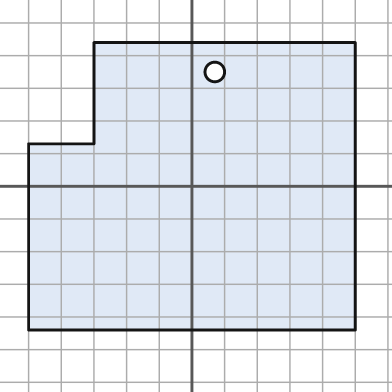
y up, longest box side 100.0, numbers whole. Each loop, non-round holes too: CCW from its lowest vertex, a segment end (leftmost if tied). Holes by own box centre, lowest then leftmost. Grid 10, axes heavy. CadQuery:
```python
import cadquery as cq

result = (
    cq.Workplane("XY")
    .moveTo(-50.0, -44.0)
    .lineTo(50.0, -44.0)
    .lineTo(50.0, 44.0)
    .lineTo(-30.0, 44.0)
    .lineTo(-30.0, 13.0)
    .lineTo(-50.0, 13.0)
    .close()
    .moveTo(7.0, 35.0)
    .circle(3.0)
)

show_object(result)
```